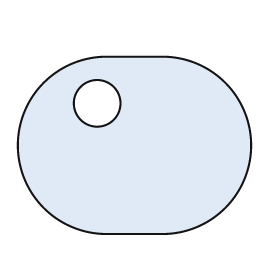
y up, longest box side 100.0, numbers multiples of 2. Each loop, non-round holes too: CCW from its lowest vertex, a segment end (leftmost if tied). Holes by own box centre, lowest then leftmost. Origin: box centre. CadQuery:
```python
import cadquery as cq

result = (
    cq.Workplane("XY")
    .moveTo(-12.0, -38.0)
    .lineTo(12.0, -38.0)
    .threePointArc((50.0, 0.0), (12.0, 38.0))
    .lineTo(-12.0, 38.0)
    .threePointArc((-50.0, 0.0), (-12.0, -38.0))
    .close()
    .moveTo(-16.0, 18.0)
    .circle(10.0)
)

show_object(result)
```